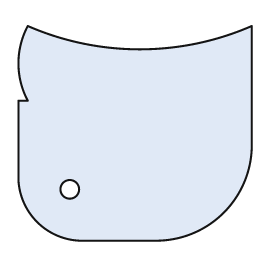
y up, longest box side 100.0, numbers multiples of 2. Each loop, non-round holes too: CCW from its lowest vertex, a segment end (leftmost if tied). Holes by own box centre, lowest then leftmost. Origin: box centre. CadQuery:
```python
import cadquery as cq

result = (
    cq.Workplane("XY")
    .moveTo(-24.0, -46.0)
    .lineTo(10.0, -46.0)
    .threePointArc((38.0, -34.0), (50.0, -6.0))
    .lineTo(50.0, 46.0)
    .threePointArc((2.0, 36.0), (-46.0, 46.0))
    .threePointArc((-50.0, 30.0), (-46.0, 14.0))
    .lineTo(-50.0, 14.0)
    .lineTo(-50.0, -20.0)
    .threePointArc((-42.0, -38.0), (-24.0, -46.0))
    .close()
    .moveTo(-28.0, -24.0)
    .circle(4.0)
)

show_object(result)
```